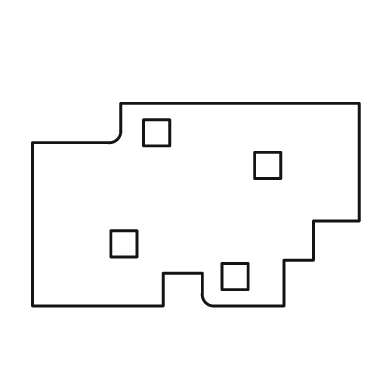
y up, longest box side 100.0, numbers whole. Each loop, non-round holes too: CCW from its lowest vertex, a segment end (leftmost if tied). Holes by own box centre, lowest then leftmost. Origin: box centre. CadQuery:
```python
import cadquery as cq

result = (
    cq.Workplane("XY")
    .moveTo(-50.0, -31.0)
    .lineTo(-10.0, -31.0)
    .lineTo(-10.0, -21.0)
    .lineTo(2.0, -21.0)
    .lineTo(2.0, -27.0)
    .threePointArc((3.0, -30.0), (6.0, -31.0))
    .lineTo(27.0, -31.0)
    .lineTo(27.0, -17.0)
    .lineTo(36.0, -17.0)
    .lineTo(36.0, -5.0)
    .lineTo(50.0, -5.0)
    .lineTo(50.0, 31.0)
    .lineTo(-23.0, 31.0)
    .lineTo(-23.0, 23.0)
    .threePointArc((-24.0, 20.0), (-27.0, 19.0))
    .lineTo(-50.0, 19.0)
    .close()
    .moveTo(8.0, -26.0)
    .lineTo(16.0, -26.0)
    .lineTo(16.0, -18.0)
    .lineTo(8.0, -18.0)
    .close()
    .moveTo(-26.0, -16.0)
    .lineTo(-18.0, -16.0)
    .lineTo(-18.0, -8.0)
    .lineTo(-26.0, -8.0)
    .close()
    .moveTo(18.0, 8.0)
    .lineTo(26.0, 8.0)
    .lineTo(26.0, 16.0)
    .lineTo(18.0, 16.0)
    .close()
    .moveTo(-16.0, 18.0)
    .lineTo(-8.0, 18.0)
    .lineTo(-8.0, 26.0)
    .lineTo(-16.0, 26.0)
    .close()
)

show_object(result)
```